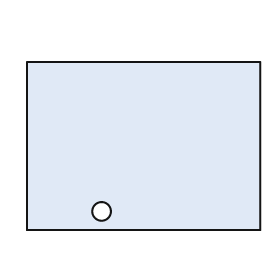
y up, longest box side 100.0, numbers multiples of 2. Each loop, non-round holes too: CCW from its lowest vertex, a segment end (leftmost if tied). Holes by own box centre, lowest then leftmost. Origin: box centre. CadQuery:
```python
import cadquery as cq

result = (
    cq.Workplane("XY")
    .moveTo(-50.0, -36.0)
    .lineTo(50.0, -36.0)
    .lineTo(50.0, 36.0)
    .lineTo(-50.0, 36.0)
    .close()
    .moveTo(-18.0, -28.0)
    .circle(4.0)
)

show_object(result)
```